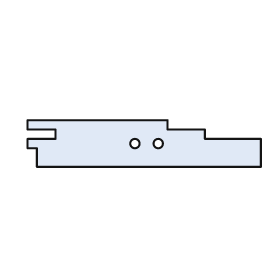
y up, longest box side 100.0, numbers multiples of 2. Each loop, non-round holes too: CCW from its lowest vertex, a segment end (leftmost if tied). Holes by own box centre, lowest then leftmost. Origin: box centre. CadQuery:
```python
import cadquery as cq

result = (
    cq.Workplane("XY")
    .moveTo(-46.0, -10.0)
    .lineTo(50.0, -10.0)
    .lineTo(50.0, 2.0)
    .lineTo(26.0, 2.0)
    .lineTo(26.0, 6.0)
    .lineTo(10.0, 6.0)
    .lineTo(10.0, 10.0)
    .lineTo(-50.0, 10.0)
    .lineTo(-50.0, 6.0)
    .lineTo(-38.0, 6.0)
    .lineTo(-38.0, 2.0)
    .lineTo(-50.0, 2.0)
    .lineTo(-50.0, -2.0)
    .lineTo(-46.0, -2.0)
    .close()
    .moveTo(-4.0, 0.0)
    .circle(2.0)
    .moveTo(6.0, 0.0)
    .circle(2.0)
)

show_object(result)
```